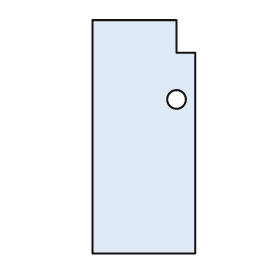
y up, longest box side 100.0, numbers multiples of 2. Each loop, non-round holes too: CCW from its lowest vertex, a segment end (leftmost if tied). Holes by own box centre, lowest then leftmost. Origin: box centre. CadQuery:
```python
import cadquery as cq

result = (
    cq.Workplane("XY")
    .moveTo(-22.0, -50.0)
    .lineTo(22.0, -50.0)
    .lineTo(22.0, 36.0)
    .lineTo(14.0, 36.0)
    .lineTo(14.0, 50.0)
    .lineTo(-22.0, 50.0)
    .close()
    .moveTo(14.0, 16.0)
    .circle(4.0)
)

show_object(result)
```